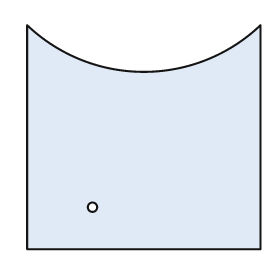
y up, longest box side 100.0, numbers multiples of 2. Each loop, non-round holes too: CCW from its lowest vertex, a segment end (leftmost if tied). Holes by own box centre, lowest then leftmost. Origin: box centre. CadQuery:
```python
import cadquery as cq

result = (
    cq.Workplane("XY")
    .moveTo(-50.0, -48.0)
    .lineTo(50.0, -48.0)
    .lineTo(50.0, 48.0)
    .threePointArc((0.0, 28.0), (-50.0, 48.0))
    .close()
    .moveTo(-22.0, -30.0)
    .circle(2.0)
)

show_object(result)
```